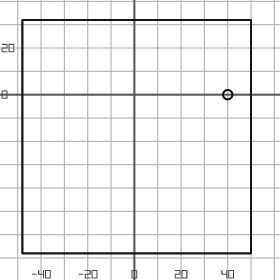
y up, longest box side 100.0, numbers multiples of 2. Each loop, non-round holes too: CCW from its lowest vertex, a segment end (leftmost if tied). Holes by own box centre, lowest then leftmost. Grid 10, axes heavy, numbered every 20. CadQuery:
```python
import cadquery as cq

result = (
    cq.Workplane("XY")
    .moveTo(-48.0, -68.0)
    .lineTo(50.0, -68.0)
    .lineTo(50.0, 32.0)
    .lineTo(-48.0, 32.0)
    .close()
    .moveTo(40.0, 0.0)
    .circle(2.0)
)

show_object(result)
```